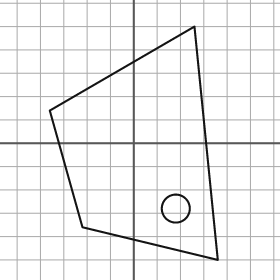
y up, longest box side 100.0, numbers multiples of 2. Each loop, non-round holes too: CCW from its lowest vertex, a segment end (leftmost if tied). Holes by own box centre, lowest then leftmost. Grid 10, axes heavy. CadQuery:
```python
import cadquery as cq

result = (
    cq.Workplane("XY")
    .moveTo(36.0, -50.0)
    .lineTo(26.0, 50.0)
    .lineTo(-36.0, 14.0)
    .lineTo(-22.0, -36.0)
    .close()
    .moveTo(18.0, -28.0)
    .circle(6.0)
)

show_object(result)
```